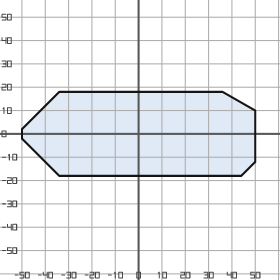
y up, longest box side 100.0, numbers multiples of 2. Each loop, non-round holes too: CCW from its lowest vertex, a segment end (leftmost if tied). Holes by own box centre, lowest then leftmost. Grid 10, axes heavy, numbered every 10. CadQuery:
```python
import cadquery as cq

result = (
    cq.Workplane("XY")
    .moveTo(-34.0, -18.0)
    .lineTo(44.0, -18.0)
    .lineTo(50.0, -12.0)
    .lineTo(50.0, 10.0)
    .lineTo(36.0, 18.0)
    .lineTo(-34.0, 18.0)
    .lineTo(-50.0, 2.0)
    .lineTo(-50.0, -2.0)
    .close()
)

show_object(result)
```